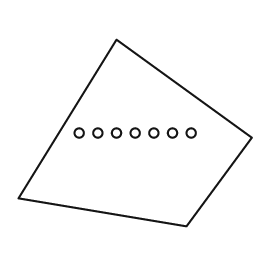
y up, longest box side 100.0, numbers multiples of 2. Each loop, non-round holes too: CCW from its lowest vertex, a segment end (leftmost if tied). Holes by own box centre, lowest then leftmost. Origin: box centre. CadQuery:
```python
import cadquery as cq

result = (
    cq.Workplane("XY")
    .moveTo(22.0, -40.0)
    .lineTo(50.0, -2.0)
    .lineTo(-8.0, 40.0)
    .lineTo(-50.0, -28.0)
    .close()
    .moveTo(-24.0, 0.0)
    .circle(2.0)
    .moveTo(-16.0, 0.0)
    .circle(2.0)
    .moveTo(-8.0, 0.0)
    .circle(2.0)
    .moveTo(0.0, 0.0)
    .circle(2.0)
    .moveTo(8.0, 0.0)
    .circle(2.0)
    .moveTo(16.0, 0.0)
    .circle(2.0)
    .moveTo(24.0, 0.0)
    .circle(2.0)
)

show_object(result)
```